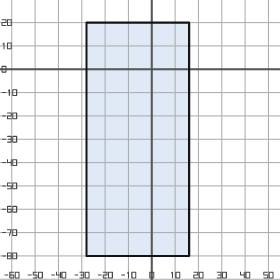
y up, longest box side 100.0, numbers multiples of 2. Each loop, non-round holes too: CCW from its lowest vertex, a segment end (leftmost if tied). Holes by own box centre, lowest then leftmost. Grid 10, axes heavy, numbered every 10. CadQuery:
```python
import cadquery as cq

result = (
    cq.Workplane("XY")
    .moveTo(-28.0, -80.0)
    .lineTo(16.0, -80.0)
    .lineTo(16.0, 20.0)
    .lineTo(-28.0, 20.0)
    .close()
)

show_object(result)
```